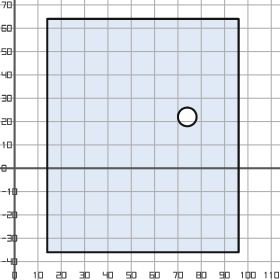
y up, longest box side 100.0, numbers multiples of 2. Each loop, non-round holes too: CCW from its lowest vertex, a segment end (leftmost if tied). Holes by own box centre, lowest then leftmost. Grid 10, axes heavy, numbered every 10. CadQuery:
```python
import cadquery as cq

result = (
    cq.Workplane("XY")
    .moveTo(14.0, -36.0)
    .lineTo(96.0, -36.0)
    .lineTo(96.0, 64.0)
    .lineTo(14.0, 64.0)
    .close()
    .moveTo(74.0, 22.0)
    .circle(4.0)
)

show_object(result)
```